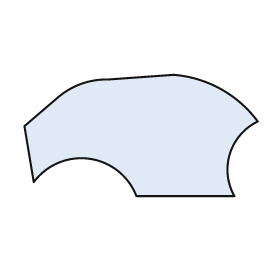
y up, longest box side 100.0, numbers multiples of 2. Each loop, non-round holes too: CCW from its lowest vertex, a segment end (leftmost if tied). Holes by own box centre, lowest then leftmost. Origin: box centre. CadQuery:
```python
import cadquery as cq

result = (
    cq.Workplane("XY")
    .moveTo(-2.0, -26.0)
    .lineTo(40.0, -26.0)
    .threePointArc((38.0, -8.0), (50.0, 6.0))
    .threePointArc((34.0, 20.0), (14.0, 26.0))
    .lineTo(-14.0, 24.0)
    .threePointArc((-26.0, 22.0), (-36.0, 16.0))
    .lineTo(-50.0, 4.0)
    .lineTo(-46.0, -20.0)
    .threePointArc((-22.0, -10.0), (-2.0, -26.0))
    .close()
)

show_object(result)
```